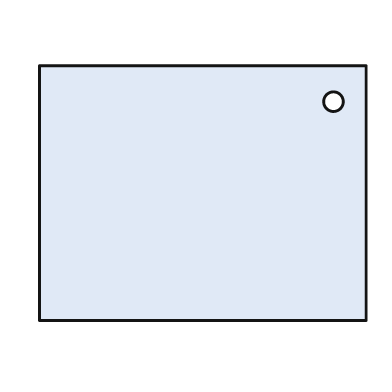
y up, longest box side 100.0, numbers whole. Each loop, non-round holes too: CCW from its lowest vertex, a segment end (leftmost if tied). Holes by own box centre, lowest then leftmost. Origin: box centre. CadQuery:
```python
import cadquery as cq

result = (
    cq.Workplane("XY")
    .moveTo(-50.0, -39.0)
    .lineTo(50.0, -39.0)
    .lineTo(50.0, 39.0)
    .lineTo(-50.0, 39.0)
    .close()
    .moveTo(40.0, 28.0)
    .circle(3.0)
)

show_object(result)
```